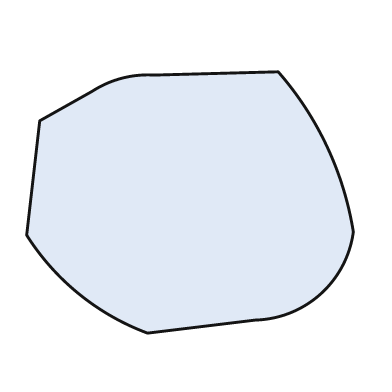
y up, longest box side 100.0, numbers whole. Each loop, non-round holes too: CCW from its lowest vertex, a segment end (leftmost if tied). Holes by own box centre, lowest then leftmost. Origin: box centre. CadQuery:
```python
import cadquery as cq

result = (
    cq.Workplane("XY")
    .moveTo(-13.0, -40.0)
    .lineTo(20.0, -36.0)
    .threePointArc((40.0, -28.0), (50.0, -9.0))
    .threePointArc((42.0, 17.0), (27.0, 40.0))
    .lineTo(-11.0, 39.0)
    .threePointArc((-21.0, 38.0), (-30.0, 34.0))
    .lineTo(-46.0, 25.0)
    .lineTo(-50.0, -10.0)
    .threePointArc((-34.0, -28.0), (-13.0, -40.0))
    .close()
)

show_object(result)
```